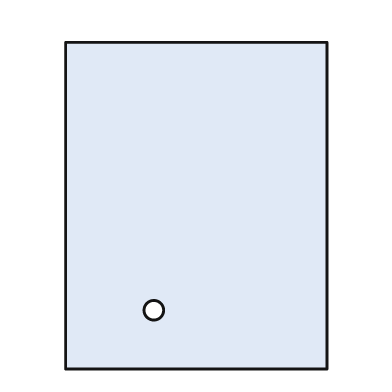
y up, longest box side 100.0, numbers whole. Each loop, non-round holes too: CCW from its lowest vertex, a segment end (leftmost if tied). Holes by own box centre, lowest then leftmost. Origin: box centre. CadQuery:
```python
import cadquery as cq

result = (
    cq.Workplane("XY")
    .moveTo(-40.0, -50.0)
    .lineTo(40.0, -50.0)
    .lineTo(40.0, 50.0)
    .lineTo(-40.0, 50.0)
    .close()
    .moveTo(-13.0, -32.0)
    .circle(3.0)
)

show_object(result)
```